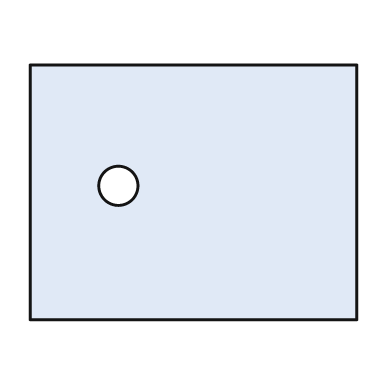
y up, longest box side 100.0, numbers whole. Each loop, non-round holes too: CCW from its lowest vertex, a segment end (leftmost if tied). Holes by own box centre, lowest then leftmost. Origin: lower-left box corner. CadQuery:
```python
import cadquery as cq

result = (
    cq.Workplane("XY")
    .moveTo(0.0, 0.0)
    .lineTo(100.0, 0.0)
    .lineTo(100.0, 78.0)
    .lineTo(0.0, 78.0)
    .close()
    .moveTo(27.0, 41.0)
    .circle(6.0)
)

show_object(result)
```